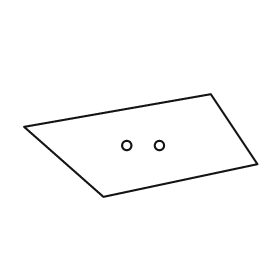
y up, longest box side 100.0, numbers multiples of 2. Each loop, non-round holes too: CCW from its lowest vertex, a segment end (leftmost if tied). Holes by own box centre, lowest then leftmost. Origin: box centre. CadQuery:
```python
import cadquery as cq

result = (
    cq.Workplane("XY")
    .moveTo(-16.0, -22.0)
    .lineTo(50.0, -8.0)
    .lineTo(30.0, 22.0)
    .lineTo(-50.0, 8.0)
    .close()
    .moveTo(-6.0, 0.0)
    .circle(2.0)
    .moveTo(8.0, 0.0)
    .circle(2.0)
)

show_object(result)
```